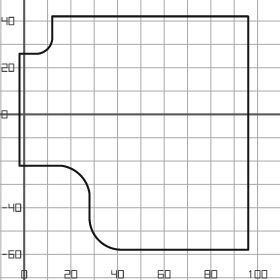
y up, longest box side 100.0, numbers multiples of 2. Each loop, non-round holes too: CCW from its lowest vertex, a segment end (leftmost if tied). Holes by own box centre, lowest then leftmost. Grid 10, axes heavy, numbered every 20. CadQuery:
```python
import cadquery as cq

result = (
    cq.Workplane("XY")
    .moveTo(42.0, -58.0)
    .lineTo(96.0, -58.0)
    .lineTo(96.0, 42.0)
    .lineTo(12.0, 42.0)
    .lineTo(12.0, 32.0)
    .threePointArc((10.0, 28.0), (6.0, 26.0))
    .lineTo(-2.0, 26.0)
    .lineTo(-2.0, -22.0)
    .lineTo(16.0, -22.0)
    .threePointArc((24.0, -26.0), (28.0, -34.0))
    .lineTo(28.0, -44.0)
    .threePointArc((32.0, -54.0), (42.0, -58.0))
    .close()
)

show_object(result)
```